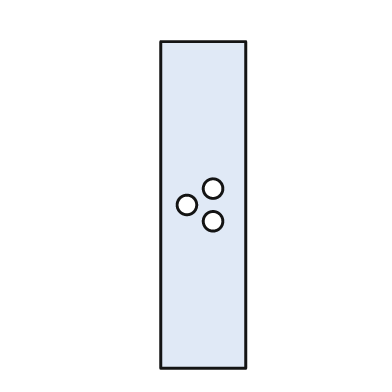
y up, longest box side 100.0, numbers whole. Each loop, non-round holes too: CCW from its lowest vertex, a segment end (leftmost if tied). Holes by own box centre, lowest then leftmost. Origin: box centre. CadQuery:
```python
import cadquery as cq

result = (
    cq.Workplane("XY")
    .moveTo(-13.0, -50.0)
    .lineTo(13.0, -50.0)
    .lineTo(13.0, 50.0)
    .lineTo(-13.0, 50.0)
    .close()
    .moveTo(3.0, -5.0)
    .circle(3.0)
    .moveTo(-5.0, 0.0)
    .circle(3.0)
    .moveTo(3.0, 5.0)
    .circle(3.0)
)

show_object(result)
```